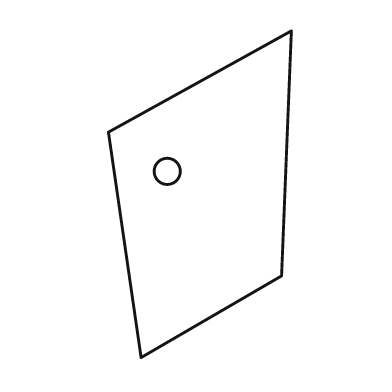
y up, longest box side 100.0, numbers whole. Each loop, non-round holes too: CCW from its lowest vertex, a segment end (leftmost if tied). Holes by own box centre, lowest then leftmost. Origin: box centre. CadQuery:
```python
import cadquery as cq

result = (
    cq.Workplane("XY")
    .moveTo(-18.0, -50.0)
    .lineTo(25.0, -25.0)
    .lineTo(28.0, 50.0)
    .lineTo(-28.0, 19.0)
    .close()
    .moveTo(-10.0, 7.0)
    .circle(4.0)
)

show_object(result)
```